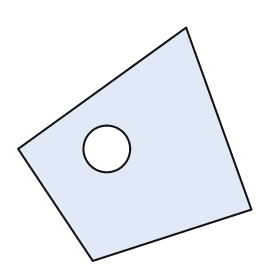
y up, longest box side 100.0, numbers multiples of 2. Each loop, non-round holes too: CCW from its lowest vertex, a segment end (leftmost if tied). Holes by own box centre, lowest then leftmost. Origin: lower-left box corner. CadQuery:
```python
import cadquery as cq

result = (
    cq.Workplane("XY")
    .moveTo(32.0, 0.0)
    .lineTo(100.0, 22.0)
    .lineTo(72.0, 100.0)
    .lineTo(0.0, 48.0)
    .close()
    .moveTo(38.0, 48.0)
    .circle(10.0)
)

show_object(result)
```